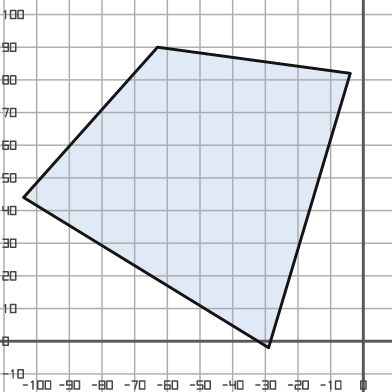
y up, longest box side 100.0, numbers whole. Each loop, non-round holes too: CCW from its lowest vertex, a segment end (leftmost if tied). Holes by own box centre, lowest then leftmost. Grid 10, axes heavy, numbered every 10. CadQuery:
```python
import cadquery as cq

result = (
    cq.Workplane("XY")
    .moveTo(-29.0, -2.0)
    .lineTo(-4.0, 82.0)
    .lineTo(-63.0, 90.0)
    .lineTo(-104.0, 44.0)
    .close()
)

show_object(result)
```